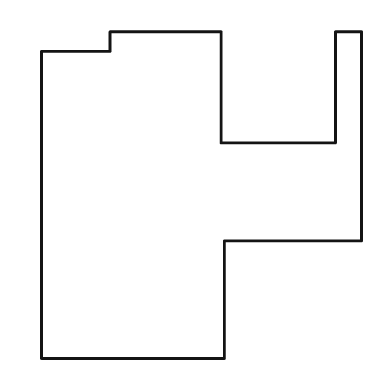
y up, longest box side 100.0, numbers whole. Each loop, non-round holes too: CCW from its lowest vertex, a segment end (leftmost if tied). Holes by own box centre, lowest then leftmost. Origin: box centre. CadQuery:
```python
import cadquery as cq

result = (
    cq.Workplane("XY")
    .moveTo(-49.0, -50.0)
    .lineTo(7.0, -50.0)
    .lineTo(7.0, -14.0)
    .lineTo(49.0, -14.0)
    .lineTo(49.0, 50.0)
    .lineTo(41.0, 50.0)
    .lineTo(41.0, 16.0)
    .lineTo(6.0, 16.0)
    .lineTo(6.0, 50.0)
    .lineTo(-28.0, 50.0)
    .lineTo(-28.0, 44.0)
    .lineTo(-49.0, 44.0)
    .close()
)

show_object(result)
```